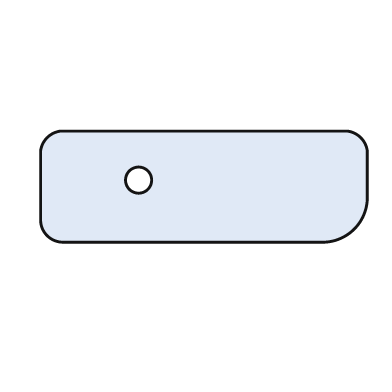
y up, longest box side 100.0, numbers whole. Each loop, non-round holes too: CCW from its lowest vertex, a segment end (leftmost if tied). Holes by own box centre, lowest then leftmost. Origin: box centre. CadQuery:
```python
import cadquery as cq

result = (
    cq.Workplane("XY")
    .moveTo(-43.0, -17.0)
    .lineTo(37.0, -17.0)
    .threePointArc((46.0, -13.0), (50.0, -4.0))
    .lineTo(50.0, 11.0)
    .threePointArc((48.0, 15.0), (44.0, 17.0))
    .lineTo(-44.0, 17.0)
    .threePointArc((-48.0, 15.0), (-50.0, 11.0))
    .lineTo(-50.0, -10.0)
    .threePointArc((-48.0, -15.0), (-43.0, -17.0))
    .close()
    .moveTo(-20.0, 2.0)
    .circle(4.0)
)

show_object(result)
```